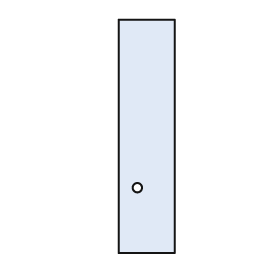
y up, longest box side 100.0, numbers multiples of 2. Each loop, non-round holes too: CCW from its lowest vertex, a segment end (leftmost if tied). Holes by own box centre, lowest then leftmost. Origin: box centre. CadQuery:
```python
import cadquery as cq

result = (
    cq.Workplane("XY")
    .moveTo(-12.0, -50.0)
    .lineTo(12.0, -50.0)
    .lineTo(12.0, 50.0)
    .lineTo(-12.0, 50.0)
    .close()
    .moveTo(-4.0, -22.0)
    .circle(2.0)
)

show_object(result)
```